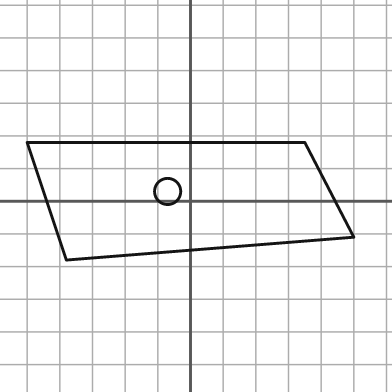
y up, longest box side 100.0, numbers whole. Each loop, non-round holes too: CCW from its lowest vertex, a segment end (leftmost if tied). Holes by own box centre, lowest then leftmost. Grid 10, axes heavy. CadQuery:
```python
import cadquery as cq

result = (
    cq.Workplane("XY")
    .moveTo(-38.0, -18.0)
    .lineTo(50.0, -11.0)
    .lineTo(35.0, 18.0)
    .lineTo(-50.0, 18.0)
    .close()
    .moveTo(-7.0, 3.0)
    .circle(4.0)
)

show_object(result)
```